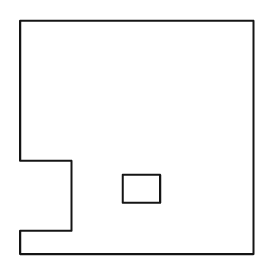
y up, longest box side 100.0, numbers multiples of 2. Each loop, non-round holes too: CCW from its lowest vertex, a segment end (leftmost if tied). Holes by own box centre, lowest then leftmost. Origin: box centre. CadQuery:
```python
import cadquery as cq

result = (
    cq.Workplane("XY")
    .moveTo(-50.0, -50.0)
    .lineTo(50.0, -50.0)
    .lineTo(50.0, 50.0)
    .lineTo(-50.0, 50.0)
    .lineTo(-50.0, -10.0)
    .lineTo(-28.0, -10.0)
    .lineTo(-28.0, -40.0)
    .lineTo(-50.0, -40.0)
    .close()
    .moveTo(-6.0, -28.0)
    .lineTo(10.0, -28.0)
    .lineTo(10.0, -16.0)
    .lineTo(-6.0, -16.0)
    .close()
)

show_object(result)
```